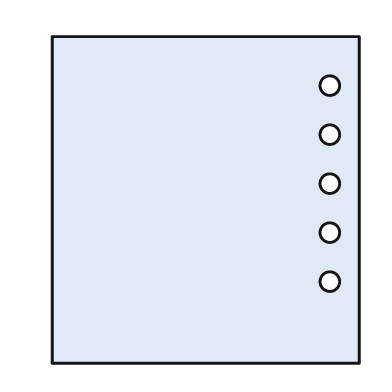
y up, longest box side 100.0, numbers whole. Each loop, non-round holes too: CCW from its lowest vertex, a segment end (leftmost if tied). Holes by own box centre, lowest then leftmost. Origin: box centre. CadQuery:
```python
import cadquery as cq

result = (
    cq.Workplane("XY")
    .moveTo(-47.0, -50.0)
    .lineTo(47.0, -50.0)
    .lineTo(47.0, 50.0)
    .lineTo(-47.0, 50.0)
    .close()
    .moveTo(38.0, -25.0)
    .circle(3.0)
    .moveTo(38.0, -10.0)
    .circle(3.0)
    .moveTo(38.0, 5.0)
    .circle(3.0)
    .moveTo(38.0, 20.0)
    .circle(3.0)
    .moveTo(38.0, 35.0)
    .circle(3.0)
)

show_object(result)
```